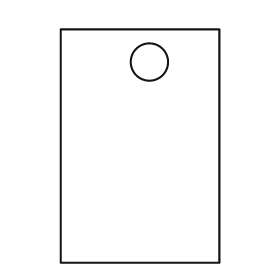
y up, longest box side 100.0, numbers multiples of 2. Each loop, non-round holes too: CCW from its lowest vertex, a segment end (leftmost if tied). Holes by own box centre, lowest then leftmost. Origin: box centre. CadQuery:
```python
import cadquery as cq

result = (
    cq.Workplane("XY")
    .moveTo(-34.0, -50.0)
    .lineTo(34.0, -50.0)
    .lineTo(34.0, 50.0)
    .lineTo(-34.0, 50.0)
    .close()
    .moveTo(4.0, 36.0)
    .circle(8.0)
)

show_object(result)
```